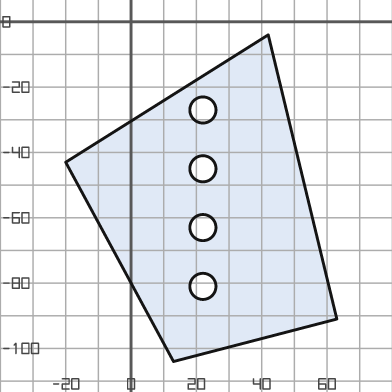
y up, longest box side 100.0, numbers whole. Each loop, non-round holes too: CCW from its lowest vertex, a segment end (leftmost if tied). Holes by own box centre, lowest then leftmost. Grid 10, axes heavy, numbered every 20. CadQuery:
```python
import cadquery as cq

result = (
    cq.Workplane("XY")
    .moveTo(13.0, -104.0)
    .lineTo(63.0, -91.0)
    .lineTo(42.0, -4.0)
    .lineTo(-20.0, -43.0)
    .close()
    .moveTo(22.0, -81.0)
    .circle(4.0)
    .moveTo(22.0, -63.0)
    .circle(4.0)
    .moveTo(22.0, -45.0)
    .circle(4.0)
    .moveTo(22.0, -27.0)
    .circle(4.0)
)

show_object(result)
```